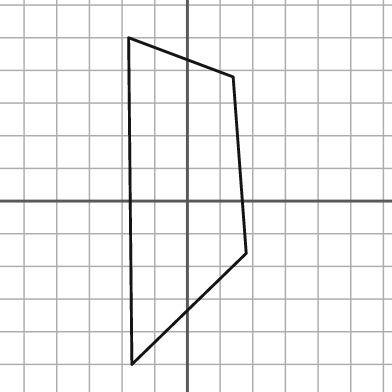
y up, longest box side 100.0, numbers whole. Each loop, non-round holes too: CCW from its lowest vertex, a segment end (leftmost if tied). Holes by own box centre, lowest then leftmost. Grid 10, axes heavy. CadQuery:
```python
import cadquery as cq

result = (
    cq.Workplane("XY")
    .moveTo(-17.0, -50.0)
    .lineTo(18.0, -16.0)
    .lineTo(14.0, 38.0)
    .lineTo(-18.0, 50.0)
    .close()
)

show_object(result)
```